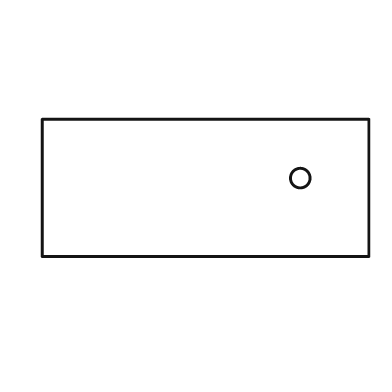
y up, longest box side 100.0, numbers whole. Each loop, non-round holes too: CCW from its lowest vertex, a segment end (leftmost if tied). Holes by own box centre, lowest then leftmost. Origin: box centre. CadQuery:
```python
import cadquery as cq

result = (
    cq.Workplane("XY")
    .moveTo(-50.0, -21.0)
    .lineTo(50.0, -21.0)
    .lineTo(50.0, 21.0)
    .lineTo(-50.0, 21.0)
    .close()
    .moveTo(29.0, 3.0)
    .circle(3.0)
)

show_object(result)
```